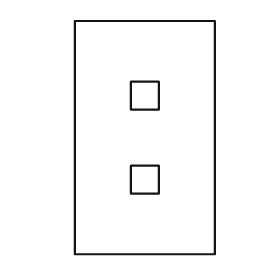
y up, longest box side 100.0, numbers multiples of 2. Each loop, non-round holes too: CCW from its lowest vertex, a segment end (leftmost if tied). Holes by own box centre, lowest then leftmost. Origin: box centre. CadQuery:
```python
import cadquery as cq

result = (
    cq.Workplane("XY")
    .moveTo(-30.0, -50.0)
    .lineTo(30.0, -50.0)
    .lineTo(30.0, 50.0)
    .lineTo(-30.0, 50.0)
    .close()
    .moveTo(-6.0, -24.0)
    .lineTo(6.0, -24.0)
    .lineTo(6.0, -12.0)
    .lineTo(-6.0, -12.0)
    .close()
    .moveTo(-6.0, 12.0)
    .lineTo(6.0, 12.0)
    .lineTo(6.0, 24.0)
    .lineTo(-6.0, 24.0)
    .close()
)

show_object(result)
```